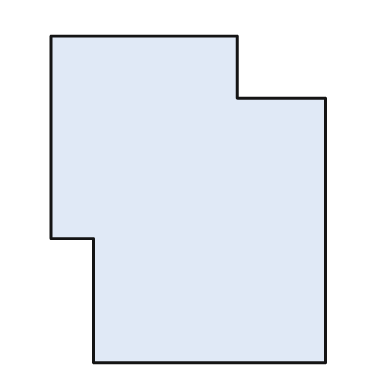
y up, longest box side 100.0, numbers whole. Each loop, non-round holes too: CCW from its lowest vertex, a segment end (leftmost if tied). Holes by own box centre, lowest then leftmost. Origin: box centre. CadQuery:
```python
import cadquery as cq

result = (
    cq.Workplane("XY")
    .moveTo(-29.0, -50.0)
    .lineTo(42.0, -50.0)
    .lineTo(42.0, 31.0)
    .lineTo(15.0, 31.0)
    .lineTo(15.0, 50.0)
    .lineTo(-42.0, 50.0)
    .lineTo(-42.0, -12.0)
    .lineTo(-29.0, -12.0)
    .close()
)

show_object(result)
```